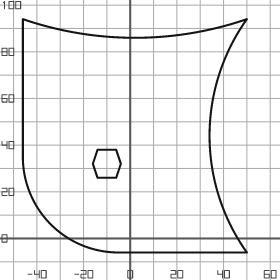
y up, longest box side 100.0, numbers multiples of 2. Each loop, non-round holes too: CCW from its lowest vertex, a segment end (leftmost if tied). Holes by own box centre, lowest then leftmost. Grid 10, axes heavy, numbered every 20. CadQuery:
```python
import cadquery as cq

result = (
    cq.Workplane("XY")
    .moveTo(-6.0, -6.0)
    .lineTo(50.0, -6.0)
    .threePointArc((34.0, 44.0), (50.0, 94.0))
    .threePointArc((2.0, 86.0), (-46.0, 94.0))
    .lineTo(-46.0, 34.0)
    .threePointArc((-34.0, 6.0), (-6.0, -6.0))
    .close()
    .moveTo(-14.0, 26.0)
    .lineTo(-6.0, 26.0)
    .lineTo(-4.0, 32.0)
    .lineTo(-6.0, 38.0)
    .lineTo(-14.0, 38.0)
    .lineTo(-16.0, 32.0)
    .close()
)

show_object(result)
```